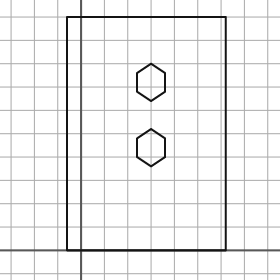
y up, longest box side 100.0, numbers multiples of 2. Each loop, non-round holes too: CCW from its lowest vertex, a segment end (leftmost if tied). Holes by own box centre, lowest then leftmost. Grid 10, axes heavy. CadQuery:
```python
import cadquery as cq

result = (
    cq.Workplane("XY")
    .moveTo(-6.0, 0.0)
    .lineTo(62.0, 0.0)
    .lineTo(62.0, 100.0)
    .lineTo(-6.0, 100.0)
    .close()
    .moveTo(30.0, 36.0)
    .lineTo(36.0, 40.0)
    .lineTo(36.0, 48.0)
    .lineTo(30.0, 52.0)
    .lineTo(24.0, 48.0)
    .lineTo(24.0, 40.0)
    .close()
    .moveTo(30.0, 64.0)
    .lineTo(36.0, 68.0)
    .lineTo(36.0, 76.0)
    .lineTo(30.0, 80.0)
    .lineTo(24.0, 76.0)
    .lineTo(24.0, 68.0)
    .close()
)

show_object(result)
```